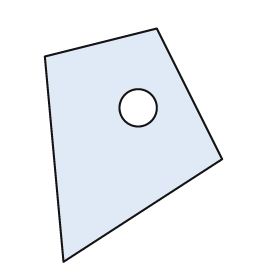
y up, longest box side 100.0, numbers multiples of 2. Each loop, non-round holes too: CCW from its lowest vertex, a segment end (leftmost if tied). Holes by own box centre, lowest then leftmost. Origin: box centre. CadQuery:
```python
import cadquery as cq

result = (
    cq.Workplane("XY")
    .moveTo(-30.0, -50.0)
    .lineTo(38.0, -6.0)
    .lineTo(10.0, 50.0)
    .lineTo(-38.0, 38.0)
    .close()
    .moveTo(2.0, 16.0)
    .circle(8.0)
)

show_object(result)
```